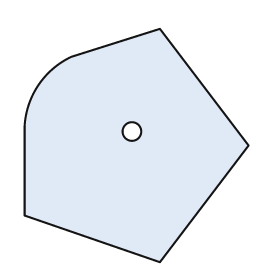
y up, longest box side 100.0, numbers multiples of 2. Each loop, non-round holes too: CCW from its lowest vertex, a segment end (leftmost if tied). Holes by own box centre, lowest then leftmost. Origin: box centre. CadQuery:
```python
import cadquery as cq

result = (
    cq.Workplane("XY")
    .moveTo(10.0, -50.0)
    .lineTo(48.0, 0.0)
    .lineTo(10.0, 50.0)
    .lineTo(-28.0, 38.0)
    .threePointArc((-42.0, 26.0), (-48.0, 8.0))
    .lineTo(-48.0, -30.0)
    .close()
    .moveTo(-2.0, 6.0)
    .circle(4.0)
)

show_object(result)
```